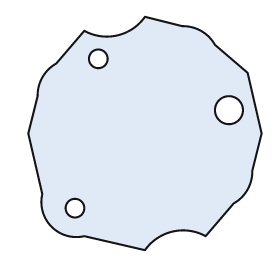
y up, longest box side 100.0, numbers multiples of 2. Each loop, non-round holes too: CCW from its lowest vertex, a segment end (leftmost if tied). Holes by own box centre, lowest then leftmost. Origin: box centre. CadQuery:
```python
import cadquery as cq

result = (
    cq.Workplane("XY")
    .moveTo(0.0, -50.0)
    .threePointArc((12.0, -42.0), (26.0, -44.0))
    .lineTo(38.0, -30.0)
    .threePointArc((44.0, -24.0), (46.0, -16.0))
    .lineTo(50.0, 0.0)
    .lineTo(44.0, 26.0)
    .lineTo(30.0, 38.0)
    .threePointArc((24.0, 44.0), (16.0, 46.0))
    .lineTo(0.0, 50.0)
    .threePointArc((-12.0, 42.0), (-26.0, 44.0))
    .lineTo(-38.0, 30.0)
    .threePointArc((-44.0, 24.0), (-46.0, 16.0))
    .lineTo(-50.0, 0.0)
    .lineTo(-44.0, -26.0)
    .threePointArc((-40.0, -40.0), (-26.0, -44.0))
    .close()
    .moveTo(-30.0, -32.0)
    .circle(4.0)
    .moveTo(36.0, 10.0)
    .circle(6.0)
    .moveTo(-20.0, 32.0)
    .circle(4.0)
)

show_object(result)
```